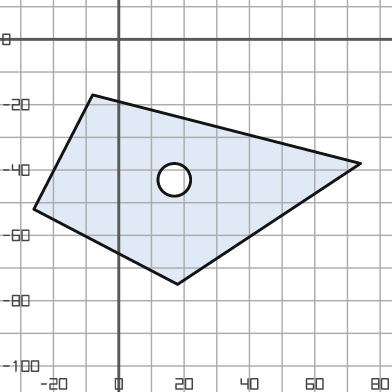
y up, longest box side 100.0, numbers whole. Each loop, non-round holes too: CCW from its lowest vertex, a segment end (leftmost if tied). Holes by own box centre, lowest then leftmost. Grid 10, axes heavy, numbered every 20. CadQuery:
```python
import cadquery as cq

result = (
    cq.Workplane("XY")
    .moveTo(18.0, -75.0)
    .lineTo(74.0, -38.0)
    .lineTo(-8.0, -17.0)
    .lineTo(-26.0, -52.0)
    .close()
    .moveTo(17.0, -43.0)
    .circle(5.0)
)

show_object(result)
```